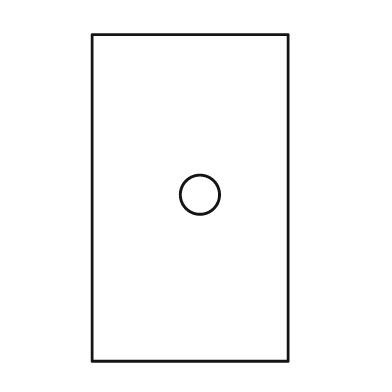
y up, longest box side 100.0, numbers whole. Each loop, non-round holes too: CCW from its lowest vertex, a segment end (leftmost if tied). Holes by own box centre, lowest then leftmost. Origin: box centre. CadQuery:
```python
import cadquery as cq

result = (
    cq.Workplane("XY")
    .moveTo(-30.0, -50.0)
    .lineTo(30.0, -50.0)
    .lineTo(30.0, 50.0)
    .lineTo(-30.0, 50.0)
    .close()
    .moveTo(3.0, 1.0)
    .circle(6.0)
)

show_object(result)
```